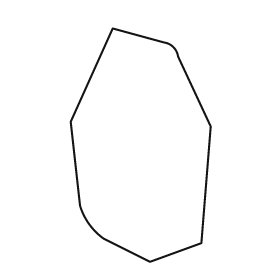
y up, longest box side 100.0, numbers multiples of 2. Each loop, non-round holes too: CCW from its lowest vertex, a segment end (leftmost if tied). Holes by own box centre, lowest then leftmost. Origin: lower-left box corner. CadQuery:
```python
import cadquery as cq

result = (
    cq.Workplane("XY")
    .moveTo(34.0, 0.0)
    .lineTo(56.0, 8.0)
    .lineTo(60.0, 58.0)
    .lineTo(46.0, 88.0)
    .threePointArc((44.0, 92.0), (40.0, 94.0))
    .lineTo(18.0, 100.0)
    .lineTo(0.0, 60.0)
    .lineTo(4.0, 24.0)
    .threePointArc((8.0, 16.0), (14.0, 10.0))
    .close()
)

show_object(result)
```